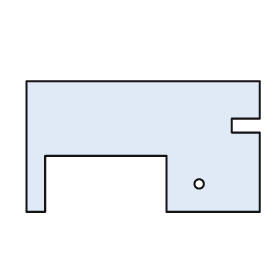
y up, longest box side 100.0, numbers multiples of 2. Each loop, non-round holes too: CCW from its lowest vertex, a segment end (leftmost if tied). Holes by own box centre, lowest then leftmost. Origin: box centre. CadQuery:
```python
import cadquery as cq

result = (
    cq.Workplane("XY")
    .moveTo(-50.0, -28.0)
    .lineTo(-42.0, -28.0)
    .lineTo(-42.0, -4.0)
    .lineTo(10.0, -4.0)
    .lineTo(10.0, -28.0)
    .lineTo(50.0, -28.0)
    .lineTo(50.0, 6.0)
    .lineTo(38.0, 6.0)
    .lineTo(38.0, 12.0)
    .lineTo(50.0, 12.0)
    .lineTo(50.0, 28.0)
    .lineTo(-50.0, 28.0)
    .close()
    .moveTo(24.0, -16.0)
    .circle(2.0)
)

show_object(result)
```